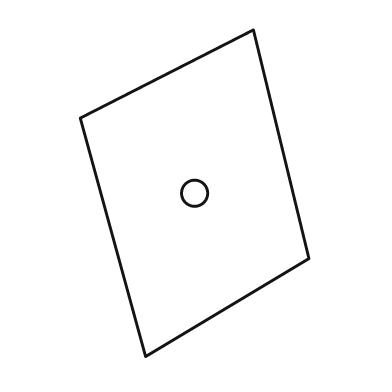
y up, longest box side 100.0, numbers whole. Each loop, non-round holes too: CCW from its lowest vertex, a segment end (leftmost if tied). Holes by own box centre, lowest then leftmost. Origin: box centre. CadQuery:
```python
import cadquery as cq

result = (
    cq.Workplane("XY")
    .moveTo(-15.0, -50.0)
    .lineTo(35.0, -20.0)
    .lineTo(18.0, 50.0)
    .lineTo(-35.0, 23.0)
    .close()
    .moveTo(0.0, 0.0)
    .circle(4.0)
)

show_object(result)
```